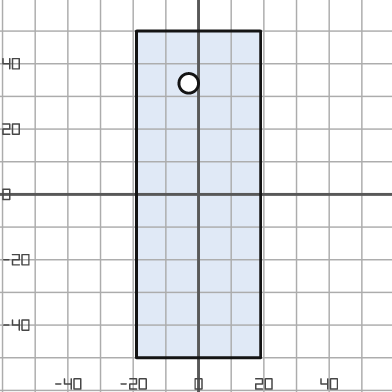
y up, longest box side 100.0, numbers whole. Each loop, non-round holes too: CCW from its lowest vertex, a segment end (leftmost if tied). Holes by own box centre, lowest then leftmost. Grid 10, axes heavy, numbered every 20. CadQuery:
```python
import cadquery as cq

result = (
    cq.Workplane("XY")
    .moveTo(-19.0, -50.0)
    .lineTo(19.0, -50.0)
    .lineTo(19.0, 50.0)
    .lineTo(-19.0, 50.0)
    .close()
    .moveTo(-3.0, 34.0)
    .circle(3.0)
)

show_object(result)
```